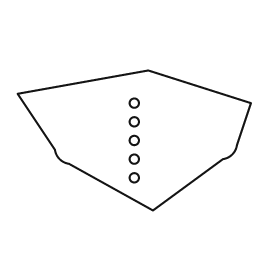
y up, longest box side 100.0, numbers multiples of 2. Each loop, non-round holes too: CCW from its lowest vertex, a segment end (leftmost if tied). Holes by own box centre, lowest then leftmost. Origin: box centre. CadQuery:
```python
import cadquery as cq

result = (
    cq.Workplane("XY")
    .moveTo(8.0, -30.0)
    .lineTo(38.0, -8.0)
    .threePointArc((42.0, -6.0), (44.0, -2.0))
    .lineTo(50.0, 16.0)
    .lineTo(6.0, 30.0)
    .lineTo(-50.0, 20.0)
    .lineTo(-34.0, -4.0)
    .threePointArc((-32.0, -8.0), (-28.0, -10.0))
    .close()
    .moveTo(0.0, -16.0)
    .circle(2.0)
    .moveTo(0.0, -8.0)
    .circle(2.0)
    .moveTo(0.0, 0.0)
    .circle(2.0)
    .moveTo(0.0, 8.0)
    .circle(2.0)
    .moveTo(0.0, 16.0)
    .circle(2.0)
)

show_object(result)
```